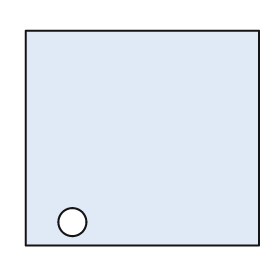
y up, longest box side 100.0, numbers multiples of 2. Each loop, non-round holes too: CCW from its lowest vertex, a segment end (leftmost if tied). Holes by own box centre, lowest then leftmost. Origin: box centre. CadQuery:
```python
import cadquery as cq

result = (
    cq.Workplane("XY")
    .moveTo(-50.0, -46.0)
    .lineTo(50.0, -46.0)
    .lineTo(50.0, 46.0)
    .lineTo(-50.0, 46.0)
    .close()
    .moveTo(-30.0, -36.0)
    .circle(6.0)
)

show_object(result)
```